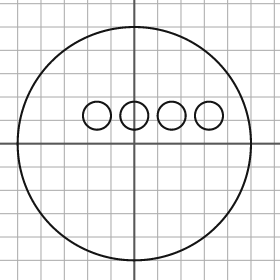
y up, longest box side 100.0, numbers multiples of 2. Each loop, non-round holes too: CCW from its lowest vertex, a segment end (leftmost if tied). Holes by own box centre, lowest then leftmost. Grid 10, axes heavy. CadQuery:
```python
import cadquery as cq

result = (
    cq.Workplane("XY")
    .moveTo(0.0, 0.0)
    .circle(50.0)
    .moveTo(-16.0, 12.0)
    .circle(6.0)
    .moveTo(0.0, 12.0)
    .circle(6.0)
    .moveTo(16.0, 12.0)
    .circle(6.0)
    .moveTo(32.0, 12.0)
    .circle(6.0)
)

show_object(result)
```